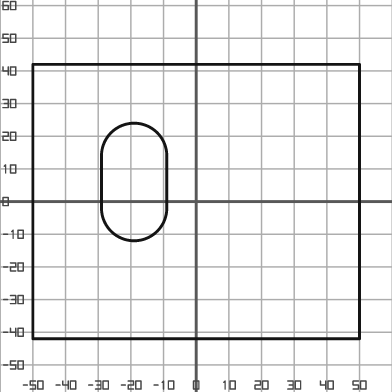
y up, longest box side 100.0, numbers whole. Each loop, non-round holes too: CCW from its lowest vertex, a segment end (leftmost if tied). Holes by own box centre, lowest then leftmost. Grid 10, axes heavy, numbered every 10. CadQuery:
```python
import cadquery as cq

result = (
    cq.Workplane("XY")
    .moveTo(-50.0, -42.0)
    .lineTo(50.0, -42.0)
    .lineTo(50.0, 42.0)
    .lineTo(-50.0, 42.0)
    .close()
    .moveTo(-29.0, -2.0)
    .threePointArc((-19.0, -12.0), (-9.0, -2.0))
    .lineTo(-9.0, 14.0)
    .threePointArc((-19.0, 24.0), (-29.0, 14.0))
    .close()
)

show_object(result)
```